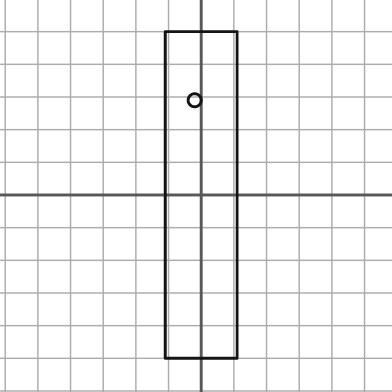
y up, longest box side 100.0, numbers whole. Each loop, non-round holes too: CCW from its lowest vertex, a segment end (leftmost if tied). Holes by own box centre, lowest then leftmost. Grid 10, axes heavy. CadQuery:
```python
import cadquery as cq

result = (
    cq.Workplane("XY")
    .moveTo(-11.0, -50.0)
    .lineTo(11.0, -50.0)
    .lineTo(11.0, 50.0)
    .lineTo(-11.0, 50.0)
    .close()
    .moveTo(-2.0, 29.0)
    .circle(2.0)
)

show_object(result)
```